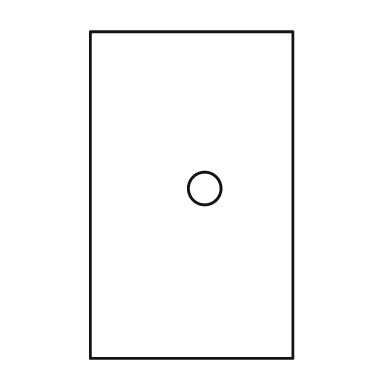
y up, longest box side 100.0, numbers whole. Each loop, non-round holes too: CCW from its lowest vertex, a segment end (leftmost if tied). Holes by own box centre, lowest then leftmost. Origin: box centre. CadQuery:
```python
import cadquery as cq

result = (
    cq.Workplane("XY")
    .moveTo(-31.0, -50.0)
    .lineTo(31.0, -50.0)
    .lineTo(31.0, 50.0)
    .lineTo(-31.0, 50.0)
    .close()
    .moveTo(4.0, 2.0)
    .circle(5.0)
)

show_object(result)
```